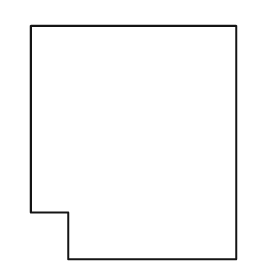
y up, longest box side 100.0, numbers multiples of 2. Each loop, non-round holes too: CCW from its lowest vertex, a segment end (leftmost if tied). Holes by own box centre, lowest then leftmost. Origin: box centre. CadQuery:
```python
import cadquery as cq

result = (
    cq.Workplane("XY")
    .moveTo(-28.0, -50.0)
    .lineTo(44.0, -50.0)
    .lineTo(44.0, 50.0)
    .lineTo(-44.0, 50.0)
    .lineTo(-44.0, -30.0)
    .lineTo(-28.0, -30.0)
    .close()
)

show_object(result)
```